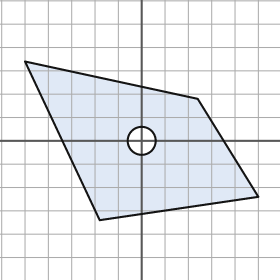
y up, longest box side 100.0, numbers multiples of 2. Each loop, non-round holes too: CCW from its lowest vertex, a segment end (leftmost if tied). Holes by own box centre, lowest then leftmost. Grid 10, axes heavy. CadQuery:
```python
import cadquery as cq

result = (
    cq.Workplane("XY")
    .moveTo(-18.0, -34.0)
    .lineTo(50.0, -24.0)
    .lineTo(24.0, 18.0)
    .lineTo(-50.0, 34.0)
    .close()
    .moveTo(0.0, 0.0)
    .circle(6.0)
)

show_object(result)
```